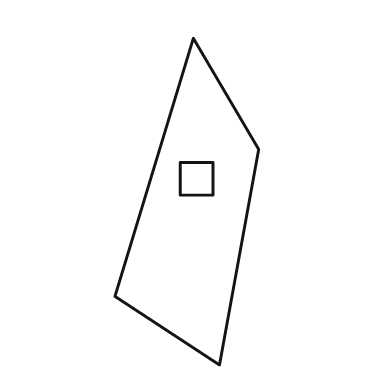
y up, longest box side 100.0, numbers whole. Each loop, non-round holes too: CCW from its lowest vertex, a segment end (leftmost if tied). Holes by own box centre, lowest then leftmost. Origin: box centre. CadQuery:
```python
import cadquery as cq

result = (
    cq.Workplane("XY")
    .moveTo(10.0, -50.0)
    .lineTo(22.0, 16.0)
    .lineTo(2.0, 50.0)
    .lineTo(-22.0, -29.0)
    .close()
    .moveTo(-2.0, 2.0)
    .lineTo(8.0, 2.0)
    .lineTo(8.0, 12.0)
    .lineTo(-2.0, 12.0)
    .close()
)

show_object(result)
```